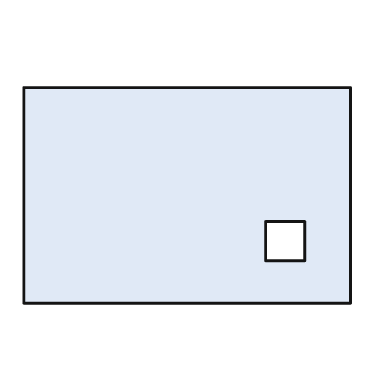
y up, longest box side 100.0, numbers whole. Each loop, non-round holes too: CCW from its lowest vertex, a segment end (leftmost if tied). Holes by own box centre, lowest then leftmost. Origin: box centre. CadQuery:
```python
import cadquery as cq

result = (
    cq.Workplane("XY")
    .moveTo(-50.0, -33.0)
    .lineTo(50.0, -33.0)
    .lineTo(50.0, 33.0)
    .lineTo(-50.0, 33.0)
    .close()
    .moveTo(24.0, -20.0)
    .lineTo(36.0, -20.0)
    .lineTo(36.0, -8.0)
    .lineTo(24.0, -8.0)
    .close()
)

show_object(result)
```